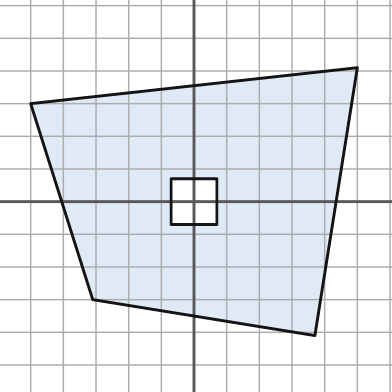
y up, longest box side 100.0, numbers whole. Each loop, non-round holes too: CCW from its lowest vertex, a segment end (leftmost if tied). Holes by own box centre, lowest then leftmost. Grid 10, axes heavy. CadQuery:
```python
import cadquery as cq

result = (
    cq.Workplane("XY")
    .moveTo(37.0, -41.0)
    .lineTo(50.0, 41.0)
    .lineTo(-50.0, 30.0)
    .lineTo(-31.0, -30.0)
    .close()
    .moveTo(-7.0, -7.0)
    .lineTo(7.0, -7.0)
    .lineTo(7.0, 7.0)
    .lineTo(-7.0, 7.0)
    .close()
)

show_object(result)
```